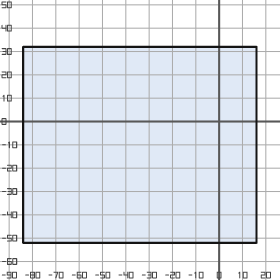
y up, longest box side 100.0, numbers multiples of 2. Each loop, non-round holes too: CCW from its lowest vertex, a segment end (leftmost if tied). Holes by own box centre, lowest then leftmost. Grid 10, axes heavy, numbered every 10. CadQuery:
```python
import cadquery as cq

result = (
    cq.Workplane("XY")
    .moveTo(-84.0, -52.0)
    .lineTo(16.0, -52.0)
    .lineTo(16.0, 32.0)
    .lineTo(-84.0, 32.0)
    .close()
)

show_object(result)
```